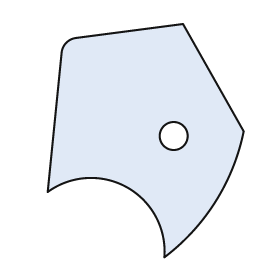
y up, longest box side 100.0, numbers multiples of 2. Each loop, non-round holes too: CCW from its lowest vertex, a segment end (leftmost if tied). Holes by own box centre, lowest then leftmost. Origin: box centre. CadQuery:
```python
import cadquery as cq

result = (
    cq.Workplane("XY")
    .moveTo(8.0, -50.0)
    .threePointArc((30.0, -26.0), (42.0, 4.0))
    .lineTo(16.0, 50.0)
    .lineTo(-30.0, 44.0)
    .threePointArc((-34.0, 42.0), (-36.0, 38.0))
    .lineTo(-42.0, -22.0)
    .threePointArc((-8.0, -20.0), (8.0, -50.0))
    .close()
    .moveTo(12.0, 2.0)
    .circle(6.0)
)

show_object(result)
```